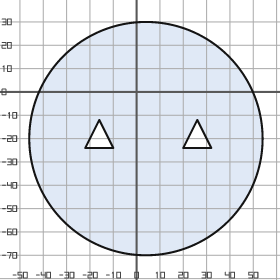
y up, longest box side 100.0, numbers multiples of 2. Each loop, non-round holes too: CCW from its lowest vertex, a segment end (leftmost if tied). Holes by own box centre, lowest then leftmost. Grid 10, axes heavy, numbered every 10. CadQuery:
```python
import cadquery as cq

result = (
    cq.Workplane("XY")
    .moveTo(4.0, -20.0)
    .circle(50.0)
    .moveTo(-22.0, -24.0)
    .lineTo(-10.0, -24.0)
    .lineTo(-16.0, -12.0)
    .close()
    .moveTo(20.0, -24.0)
    .lineTo(32.0, -24.0)
    .lineTo(26.0, -12.0)
    .close()
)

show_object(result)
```